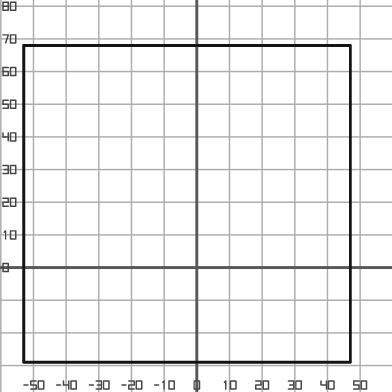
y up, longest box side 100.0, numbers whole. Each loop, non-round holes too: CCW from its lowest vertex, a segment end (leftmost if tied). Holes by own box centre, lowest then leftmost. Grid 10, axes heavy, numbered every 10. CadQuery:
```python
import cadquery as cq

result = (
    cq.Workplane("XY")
    .moveTo(-53.0, -29.0)
    .lineTo(47.0, -29.0)
    .lineTo(47.0, 68.0)
    .lineTo(-53.0, 68.0)
    .close()
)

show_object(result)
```